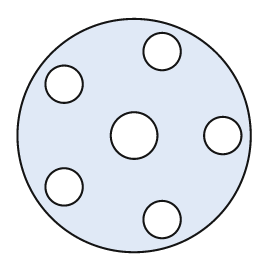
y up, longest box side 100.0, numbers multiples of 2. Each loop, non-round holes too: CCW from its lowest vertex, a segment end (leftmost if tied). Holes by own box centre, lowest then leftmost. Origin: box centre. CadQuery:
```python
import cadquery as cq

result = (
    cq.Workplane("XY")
    .moveTo(0.0, 0.0)
    .circle(50.0)
    .moveTo(12.0, -36.0)
    .circle(8.0)
    .moveTo(-30.0, -22.0)
    .circle(8.0)
    .moveTo(0.0, 0.0)
    .circle(10.0)
    .moveTo(38.0, 0.0)
    .circle(8.0)
    .moveTo(-30.0, 22.0)
    .circle(8.0)
    .moveTo(12.0, 36.0)
    .circle(8.0)
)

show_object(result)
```